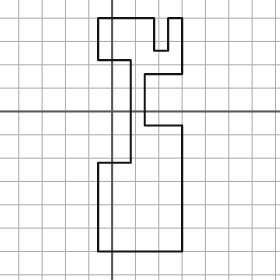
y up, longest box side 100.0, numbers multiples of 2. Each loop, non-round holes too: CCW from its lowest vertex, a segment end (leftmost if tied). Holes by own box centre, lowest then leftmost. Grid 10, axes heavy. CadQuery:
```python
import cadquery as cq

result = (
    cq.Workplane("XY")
    .moveTo(-6.0, -60.0)
    .lineTo(30.0, -60.0)
    .lineTo(30.0, -6.0)
    .lineTo(14.0, -6.0)
    .lineTo(14.0, 16.0)
    .lineTo(30.0, 16.0)
    .lineTo(30.0, 40.0)
    .lineTo(24.0, 40.0)
    .lineTo(24.0, 26.0)
    .lineTo(18.0, 26.0)
    .lineTo(18.0, 40.0)
    .lineTo(-6.0, 40.0)
    .lineTo(-6.0, 22.0)
    .lineTo(8.0, 22.0)
    .lineTo(8.0, -22.0)
    .lineTo(-6.0, -22.0)
    .close()
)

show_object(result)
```